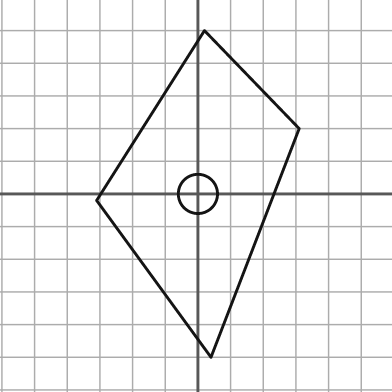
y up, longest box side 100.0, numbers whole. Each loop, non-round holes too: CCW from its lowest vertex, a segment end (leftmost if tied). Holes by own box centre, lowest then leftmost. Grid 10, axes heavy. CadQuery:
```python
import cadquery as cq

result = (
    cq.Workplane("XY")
    .moveTo(4.0, -50.0)
    .lineTo(31.0, 20.0)
    .lineTo(2.0, 50.0)
    .lineTo(-31.0, -2.0)
    .close()
    .moveTo(0.0, 0.0)
    .circle(6.0)
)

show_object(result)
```